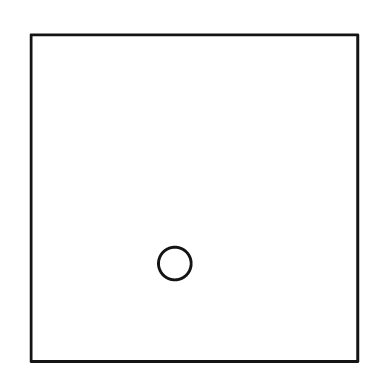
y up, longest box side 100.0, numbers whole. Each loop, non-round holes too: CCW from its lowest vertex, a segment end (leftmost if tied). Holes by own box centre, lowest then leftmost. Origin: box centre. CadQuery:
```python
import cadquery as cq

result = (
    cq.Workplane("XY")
    .moveTo(-50.0, -50.0)
    .lineTo(50.0, -50.0)
    .lineTo(50.0, 50.0)
    .lineTo(-50.0, 50.0)
    .close()
    .moveTo(-6.0, -20.0)
    .circle(5.0)
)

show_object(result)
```